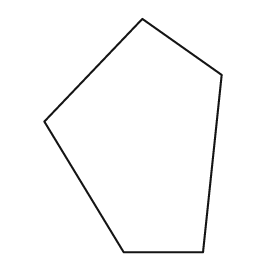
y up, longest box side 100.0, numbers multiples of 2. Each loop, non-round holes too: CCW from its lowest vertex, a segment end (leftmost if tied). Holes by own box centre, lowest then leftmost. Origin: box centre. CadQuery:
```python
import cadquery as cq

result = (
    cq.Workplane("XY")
    .moveTo(-4.0, -50.0)
    .lineTo(30.0, -50.0)
    .lineTo(38.0, 26.0)
    .lineTo(4.0, 50.0)
    .lineTo(-38.0, 6.0)
    .close()
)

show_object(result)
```